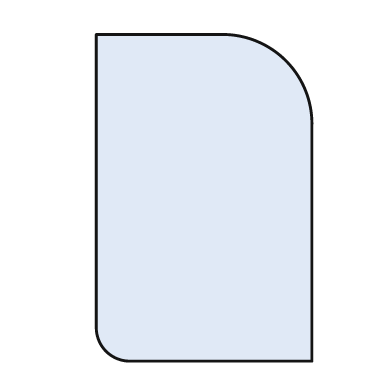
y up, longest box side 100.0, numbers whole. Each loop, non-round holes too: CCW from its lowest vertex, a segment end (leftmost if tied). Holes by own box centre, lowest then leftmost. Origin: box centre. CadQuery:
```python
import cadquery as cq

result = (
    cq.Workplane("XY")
    .moveTo(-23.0, -50.0)
    .lineTo(33.0, -50.0)
    .lineTo(33.0, 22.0)
    .threePointArc((25.0, 42.0), (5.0, 50.0))
    .lineTo(-33.0, 50.0)
    .lineTo(-33.0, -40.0)
    .threePointArc((-30.0, -47.0), (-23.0, -50.0))
    .close()
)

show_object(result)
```